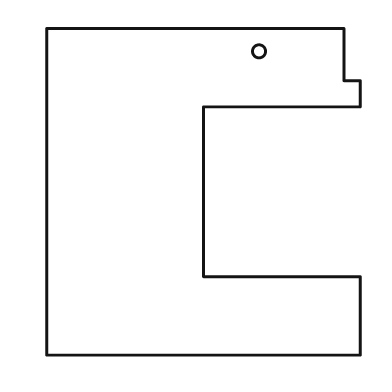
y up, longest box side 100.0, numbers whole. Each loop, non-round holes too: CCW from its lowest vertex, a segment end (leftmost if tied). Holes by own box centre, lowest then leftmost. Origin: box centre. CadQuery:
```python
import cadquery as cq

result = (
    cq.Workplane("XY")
    .moveTo(-48.0, -50.0)
    .lineTo(48.0, -50.0)
    .lineTo(48.0, -26.0)
    .lineTo(0.0, -26.0)
    .lineTo(0.0, 26.0)
    .lineTo(48.0, 26.0)
    .lineTo(48.0, 34.0)
    .lineTo(43.0, 34.0)
    .lineTo(43.0, 50.0)
    .lineTo(-48.0, 50.0)
    .close()
    .moveTo(17.0, 43.0)
    .circle(2.0)
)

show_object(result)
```